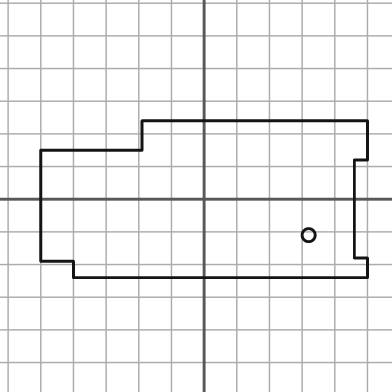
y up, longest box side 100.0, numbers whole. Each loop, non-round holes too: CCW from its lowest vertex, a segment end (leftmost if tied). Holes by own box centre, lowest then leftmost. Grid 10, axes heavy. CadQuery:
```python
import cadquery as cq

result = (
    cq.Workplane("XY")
    .moveTo(-40.0, -24.0)
    .lineTo(50.0, -24.0)
    .lineTo(50.0, -18.0)
    .lineTo(46.0, -18.0)
    .lineTo(46.0, 12.0)
    .lineTo(50.0, 12.0)
    .lineTo(50.0, 24.0)
    .lineTo(-19.0, 24.0)
    .lineTo(-19.0, 15.0)
    .lineTo(-50.0, 15.0)
    .lineTo(-50.0, -19.0)
    .lineTo(-40.0, -19.0)
    .close()
    .moveTo(32.0, -11.0)
    .circle(2.0)
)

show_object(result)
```